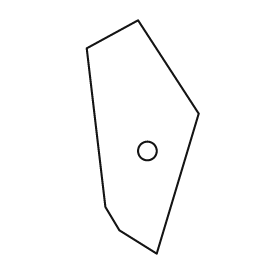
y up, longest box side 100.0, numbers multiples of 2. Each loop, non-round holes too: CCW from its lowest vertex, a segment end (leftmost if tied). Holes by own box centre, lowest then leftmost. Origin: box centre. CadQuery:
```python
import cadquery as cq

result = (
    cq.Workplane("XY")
    .moveTo(6.0, -50.0)
    .lineTo(24.0, 10.0)
    .lineTo(-2.0, 50.0)
    .lineTo(-24.0, 38.0)
    .lineTo(-16.0, -30.0)
    .lineTo(-10.0, -40.0)
    .close()
    .moveTo(2.0, -6.0)
    .circle(4.0)
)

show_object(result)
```